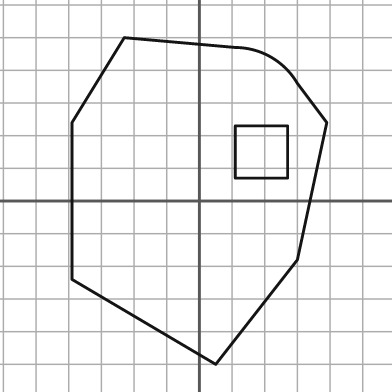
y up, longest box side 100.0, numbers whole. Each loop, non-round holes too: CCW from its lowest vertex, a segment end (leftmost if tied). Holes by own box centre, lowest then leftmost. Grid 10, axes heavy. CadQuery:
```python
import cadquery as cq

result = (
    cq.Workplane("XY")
    .moveTo(5.0, -50.0)
    .lineTo(30.0, -18.0)
    .lineTo(39.0, 24.0)
    .lineTo(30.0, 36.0)
    .threePointArc((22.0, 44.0), (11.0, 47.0))
    .lineTo(-23.0, 50.0)
    .lineTo(-39.0, 24.0)
    .lineTo(-39.0, -24.0)
    .close()
    .moveTo(11.0, 7.0)
    .lineTo(27.0, 7.0)
    .lineTo(27.0, 23.0)
    .lineTo(11.0, 23.0)
    .close()
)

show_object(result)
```